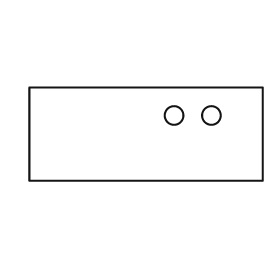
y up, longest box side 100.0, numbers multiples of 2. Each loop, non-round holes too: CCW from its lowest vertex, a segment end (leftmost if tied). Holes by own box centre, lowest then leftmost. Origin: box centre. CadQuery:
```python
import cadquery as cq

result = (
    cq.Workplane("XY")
    .moveTo(-50.0, -20.0)
    .lineTo(50.0, -20.0)
    .lineTo(50.0, 20.0)
    .lineTo(-50.0, 20.0)
    .close()
    .moveTo(12.0, 8.0)
    .circle(4.0)
    .moveTo(28.0, 8.0)
    .circle(4.0)
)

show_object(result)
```